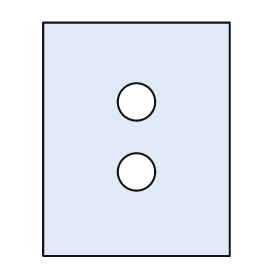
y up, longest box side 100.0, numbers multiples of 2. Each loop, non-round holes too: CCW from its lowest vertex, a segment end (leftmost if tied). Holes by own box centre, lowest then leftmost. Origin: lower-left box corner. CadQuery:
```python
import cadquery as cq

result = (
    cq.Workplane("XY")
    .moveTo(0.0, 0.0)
    .lineTo(80.0, 0.0)
    .lineTo(80.0, 100.0)
    .lineTo(0.0, 100.0)
    .close()
    .moveTo(40.0, 36.0)
    .circle(8.0)
    .moveTo(40.0, 66.0)
    .circle(8.0)
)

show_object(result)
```